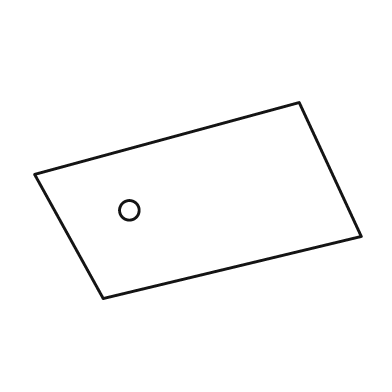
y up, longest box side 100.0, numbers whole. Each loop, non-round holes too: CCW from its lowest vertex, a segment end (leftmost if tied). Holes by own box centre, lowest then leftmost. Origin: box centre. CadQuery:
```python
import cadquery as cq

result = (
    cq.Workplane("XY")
    .moveTo(-29.0, -30.0)
    .lineTo(50.0, -11.0)
    .lineTo(31.0, 30.0)
    .lineTo(-50.0, 8.0)
    .close()
    .moveTo(-21.0, -3.0)
    .circle(3.0)
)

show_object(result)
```